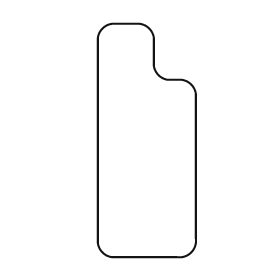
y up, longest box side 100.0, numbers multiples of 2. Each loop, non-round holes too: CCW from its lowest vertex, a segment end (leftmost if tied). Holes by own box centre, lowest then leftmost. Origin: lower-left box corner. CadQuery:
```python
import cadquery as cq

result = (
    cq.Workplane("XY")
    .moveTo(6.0, 0.0)
    .lineTo(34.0, 0.0)
    .threePointArc((40.0, 2.0), (42.0, 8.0))
    .lineTo(42.0, 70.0)
    .threePointArc((40.0, 74.0), (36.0, 76.0))
    .lineTo(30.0, 76.0)
    .threePointArc((26.0, 78.0), (24.0, 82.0))
    .lineTo(24.0, 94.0)
    .threePointArc((22.0, 98.0), (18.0, 100.0))
    .lineTo(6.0, 100.0)
    .threePointArc((2.0, 98.0), (0.0, 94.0))
    .lineTo(0.0, 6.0)
    .threePointArc((2.0, 2.0), (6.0, 0.0))
    .close()
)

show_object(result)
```